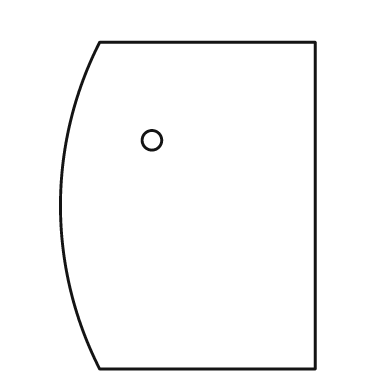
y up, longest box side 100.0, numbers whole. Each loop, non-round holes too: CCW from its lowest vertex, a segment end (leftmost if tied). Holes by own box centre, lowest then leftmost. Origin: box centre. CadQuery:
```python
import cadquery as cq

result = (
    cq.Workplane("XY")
    .moveTo(-27.0, -50.0)
    .lineTo(39.0, -50.0)
    .lineTo(39.0, 50.0)
    .lineTo(-27.0, 50.0)
    .threePointArc((-39.0, 0.0), (-27.0, -50.0))
    .close()
    .moveTo(-11.0, 20.0)
    .circle(3.0)
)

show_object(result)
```